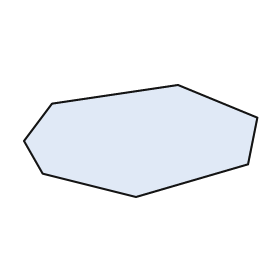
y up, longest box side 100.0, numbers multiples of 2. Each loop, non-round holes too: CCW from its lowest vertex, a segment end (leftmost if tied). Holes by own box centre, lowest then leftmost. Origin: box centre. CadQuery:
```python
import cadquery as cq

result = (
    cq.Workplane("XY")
    .moveTo(-2.0, -24.0)
    .lineTo(46.0, -10.0)
    .lineTo(50.0, 10.0)
    .lineTo(16.0, 24.0)
    .lineTo(-38.0, 16.0)
    .lineTo(-50.0, 0.0)
    .lineTo(-42.0, -14.0)
    .close()
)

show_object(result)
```